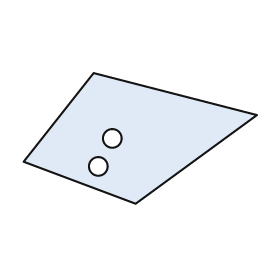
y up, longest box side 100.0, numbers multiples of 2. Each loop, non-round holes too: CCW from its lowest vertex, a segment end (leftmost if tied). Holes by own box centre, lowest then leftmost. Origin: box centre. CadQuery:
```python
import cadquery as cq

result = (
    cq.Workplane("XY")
    .moveTo(-2.0, -28.0)
    .lineTo(50.0, 10.0)
    .lineTo(-20.0, 28.0)
    .lineTo(-50.0, -10.0)
    .close()
    .moveTo(-18.0, -12.0)
    .circle(4.0)
    .moveTo(-12.0, 0.0)
    .circle(4.0)
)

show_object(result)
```